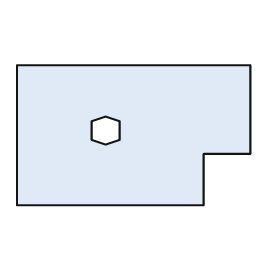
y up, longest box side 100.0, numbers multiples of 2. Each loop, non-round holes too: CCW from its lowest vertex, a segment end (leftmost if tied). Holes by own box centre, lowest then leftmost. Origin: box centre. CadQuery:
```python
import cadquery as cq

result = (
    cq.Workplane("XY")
    .moveTo(-50.0, -30.0)
    .lineTo(30.0, -30.0)
    .lineTo(30.0, -8.0)
    .lineTo(50.0, -8.0)
    .lineTo(50.0, 30.0)
    .lineTo(-50.0, 30.0)
    .close()
    .moveTo(-12.0, -4.0)
    .lineTo(-6.0, -2.0)
    .lineTo(-6.0, 6.0)
    .lineTo(-12.0, 8.0)
    .lineTo(-18.0, 6.0)
    .lineTo(-18.0, -2.0)
    .close()
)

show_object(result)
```